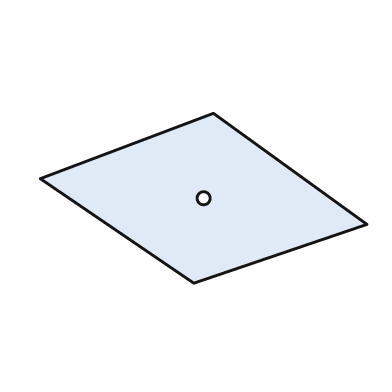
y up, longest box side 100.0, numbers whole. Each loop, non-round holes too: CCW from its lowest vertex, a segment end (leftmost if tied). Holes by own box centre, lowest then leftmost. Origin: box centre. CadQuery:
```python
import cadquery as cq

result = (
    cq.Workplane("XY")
    .moveTo(-3.0, -26.0)
    .lineTo(50.0, -8.0)
    .lineTo(3.0, 26.0)
    .lineTo(-50.0, 6.0)
    .close()
    .moveTo(0.0, 0.0)
    .circle(2.0)
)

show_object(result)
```